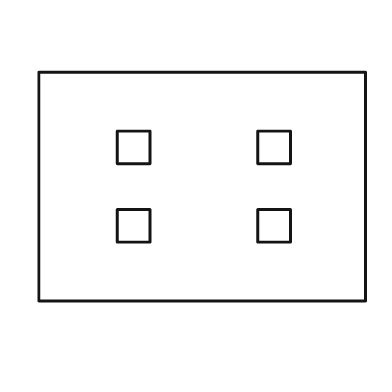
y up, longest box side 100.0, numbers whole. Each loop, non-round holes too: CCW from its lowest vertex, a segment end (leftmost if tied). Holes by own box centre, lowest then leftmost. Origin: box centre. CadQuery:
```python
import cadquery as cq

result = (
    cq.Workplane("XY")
    .moveTo(-50.0, -35.0)
    .lineTo(50.0, -35.0)
    .lineTo(50.0, 35.0)
    .lineTo(-50.0, 35.0)
    .close()
    .moveTo(-26.0, -17.0)
    .lineTo(-16.0, -17.0)
    .lineTo(-16.0, -7.0)
    .lineTo(-26.0, -7.0)
    .close()
    .moveTo(17.0, -17.0)
    .lineTo(27.0, -17.0)
    .lineTo(27.0, -7.0)
    .lineTo(17.0, -7.0)
    .close()
    .moveTo(-26.0, 7.0)
    .lineTo(-16.0, 7.0)
    .lineTo(-16.0, 17.0)
    .lineTo(-26.0, 17.0)
    .close()
    .moveTo(17.0, 7.0)
    .lineTo(27.0, 7.0)
    .lineTo(27.0, 17.0)
    .lineTo(17.0, 17.0)
    .close()
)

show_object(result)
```